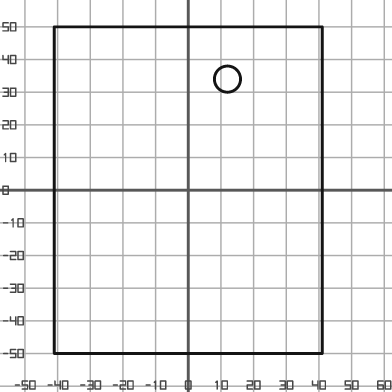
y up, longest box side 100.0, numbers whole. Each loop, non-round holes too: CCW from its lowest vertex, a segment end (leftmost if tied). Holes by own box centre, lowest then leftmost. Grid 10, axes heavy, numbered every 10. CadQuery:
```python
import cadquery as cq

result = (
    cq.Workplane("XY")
    .moveTo(-41.0, -50.0)
    .lineTo(41.0, -50.0)
    .lineTo(41.0, 50.0)
    .lineTo(-41.0, 50.0)
    .close()
    .moveTo(12.0, 34.0)
    .circle(4.0)
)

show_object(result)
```